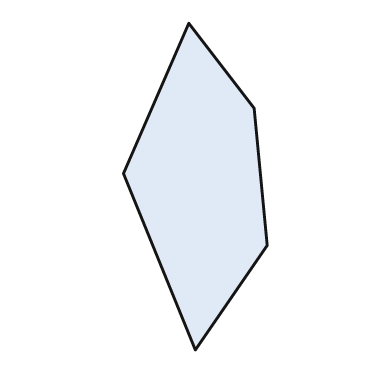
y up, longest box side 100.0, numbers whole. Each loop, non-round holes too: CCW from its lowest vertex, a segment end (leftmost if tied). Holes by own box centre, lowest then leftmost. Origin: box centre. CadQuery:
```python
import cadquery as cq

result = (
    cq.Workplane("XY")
    .moveTo(0.0, -50.0)
    .lineTo(22.0, -18.0)
    .lineTo(18.0, 24.0)
    .lineTo(-2.0, 50.0)
    .lineTo(-22.0, 4.0)
    .close()
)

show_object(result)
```